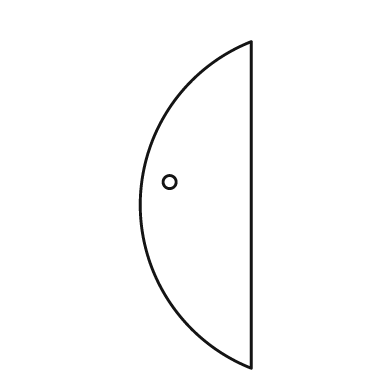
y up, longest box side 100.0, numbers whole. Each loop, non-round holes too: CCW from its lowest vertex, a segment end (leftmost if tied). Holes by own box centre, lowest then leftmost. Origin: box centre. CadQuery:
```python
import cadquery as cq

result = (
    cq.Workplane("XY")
    .moveTo(17.0, -50.0)
    .lineTo(17.0, 50.0)
    .threePointArc((-17.0, 0.0), (17.0, -50.0))
    .close()
    .moveTo(-8.0, 7.0)
    .circle(2.0)
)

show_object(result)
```